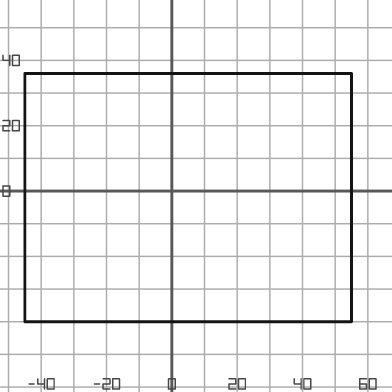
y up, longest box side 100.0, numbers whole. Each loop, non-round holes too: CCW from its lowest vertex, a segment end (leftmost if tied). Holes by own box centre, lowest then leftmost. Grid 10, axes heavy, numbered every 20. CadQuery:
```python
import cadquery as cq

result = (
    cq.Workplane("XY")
    .moveTo(-45.0, -40.0)
    .lineTo(55.0, -40.0)
    .lineTo(55.0, 36.0)
    .lineTo(-45.0, 36.0)
    .close()
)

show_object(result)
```